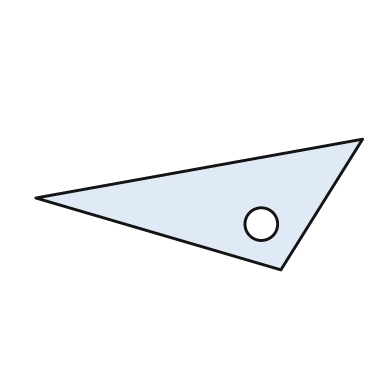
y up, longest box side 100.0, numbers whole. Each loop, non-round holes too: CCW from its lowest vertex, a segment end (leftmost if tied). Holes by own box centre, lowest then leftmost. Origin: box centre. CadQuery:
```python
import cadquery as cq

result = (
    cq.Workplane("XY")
    .moveTo(25.0, -20.0)
    .lineTo(50.0, 20.0)
    .lineTo(-50.0, 2.0)
    .close()
    .moveTo(19.0, -6.0)
    .circle(5.0)
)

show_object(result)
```